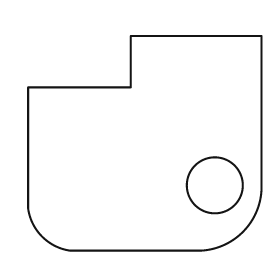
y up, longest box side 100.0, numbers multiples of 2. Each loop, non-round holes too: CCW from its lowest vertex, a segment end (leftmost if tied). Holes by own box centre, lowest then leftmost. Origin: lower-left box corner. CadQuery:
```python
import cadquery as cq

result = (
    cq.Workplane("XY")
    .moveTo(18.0, 0.0)
    .lineTo(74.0, 0.0)
    .threePointArc((92.0, 8.0), (100.0, 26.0))
    .lineTo(100.0, 92.0)
    .lineTo(44.0, 92.0)
    .lineTo(44.0, 70.0)
    .lineTo(0.0, 70.0)
    .lineTo(0.0, 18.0)
    .threePointArc((6.0, 6.0), (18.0, 0.0))
    .close()
    .moveTo(80.0, 28.0)
    .circle(12.0)
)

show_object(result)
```